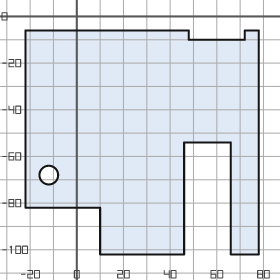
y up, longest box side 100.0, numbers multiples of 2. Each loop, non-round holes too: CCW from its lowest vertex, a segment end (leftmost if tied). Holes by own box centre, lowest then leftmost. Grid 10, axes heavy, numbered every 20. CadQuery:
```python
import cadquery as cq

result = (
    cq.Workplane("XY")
    .moveTo(10.0, -102.0)
    .lineTo(46.0, -102.0)
    .lineTo(46.0, -54.0)
    .lineTo(66.0, -54.0)
    .lineTo(66.0, -102.0)
    .lineTo(78.0, -102.0)
    .lineTo(78.0, -6.0)
    .lineTo(72.0, -6.0)
    .lineTo(72.0, -10.0)
    .lineTo(48.0, -10.0)
    .lineTo(48.0, -6.0)
    .lineTo(-22.0, -6.0)
    .lineTo(-22.0, -82.0)
    .lineTo(10.0, -82.0)
    .close()
    .moveTo(-12.0, -68.0)
    .circle(4.0)
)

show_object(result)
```